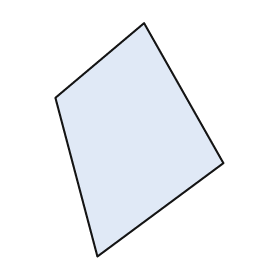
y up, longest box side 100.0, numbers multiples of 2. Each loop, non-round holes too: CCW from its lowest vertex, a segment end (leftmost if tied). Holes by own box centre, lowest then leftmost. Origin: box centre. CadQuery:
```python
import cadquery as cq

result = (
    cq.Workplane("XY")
    .moveTo(-18.0, -50.0)
    .lineTo(36.0, -10.0)
    .lineTo(2.0, 50.0)
    .lineTo(-36.0, 18.0)
    .close()
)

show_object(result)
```